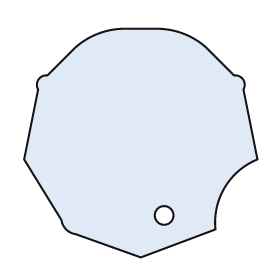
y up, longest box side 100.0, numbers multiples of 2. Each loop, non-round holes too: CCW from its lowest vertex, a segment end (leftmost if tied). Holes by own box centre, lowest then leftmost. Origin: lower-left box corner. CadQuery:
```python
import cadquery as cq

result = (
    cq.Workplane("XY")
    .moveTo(50.0, 0.0)
    .lineTo(82.0, 12.0)
    .threePointArc((86.0, 30.0), (100.0, 42.0))
    .lineTo(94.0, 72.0)
    .threePointArc((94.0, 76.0), (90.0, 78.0))
    .lineTo(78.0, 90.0)
    .threePointArc((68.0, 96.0), (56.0, 98.0))
    .lineTo(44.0, 98.0)
    .threePointArc((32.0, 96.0), (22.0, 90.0))
    .lineTo(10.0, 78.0)
    .threePointArc((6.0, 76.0), (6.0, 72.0))
    .lineTo(0.0, 42.0)
    .lineTo(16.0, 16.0)
    .threePointArc((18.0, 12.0), (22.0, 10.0))
    .close()
    .moveTo(60.0, 18.0)
    .circle(4.0)
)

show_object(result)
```